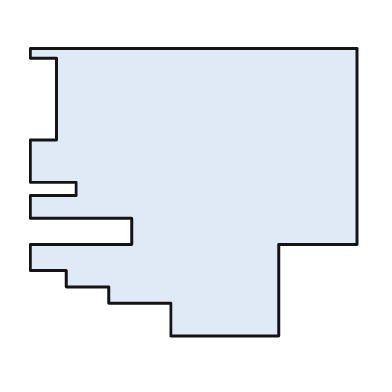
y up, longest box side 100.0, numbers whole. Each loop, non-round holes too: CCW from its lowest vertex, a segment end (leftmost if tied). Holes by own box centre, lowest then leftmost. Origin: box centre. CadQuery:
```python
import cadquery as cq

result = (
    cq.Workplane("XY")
    .moveTo(-7.0, -44.0)
    .lineTo(26.0, -44.0)
    .lineTo(26.0, -16.0)
    .lineTo(50.0, -16.0)
    .lineTo(50.0, 44.0)
    .lineTo(-50.0, 44.0)
    .lineTo(-50.0, 41.0)
    .lineTo(-42.0, 41.0)
    .lineTo(-42.0, 16.0)
    .lineTo(-50.0, 16.0)
    .lineTo(-50.0, 3.0)
    .lineTo(-36.0, 3.0)
    .lineTo(-36.0, -1.0)
    .lineTo(-50.0, -1.0)
    .lineTo(-50.0, -8.0)
    .lineTo(-19.0, -8.0)
    .lineTo(-19.0, -16.0)
    .lineTo(-50.0, -16.0)
    .lineTo(-50.0, -24.0)
    .lineTo(-39.0, -24.0)
    .lineTo(-39.0, -29.0)
    .lineTo(-26.0, -29.0)
    .lineTo(-26.0, -34.0)
    .lineTo(-7.0, -34.0)
    .close()
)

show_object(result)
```